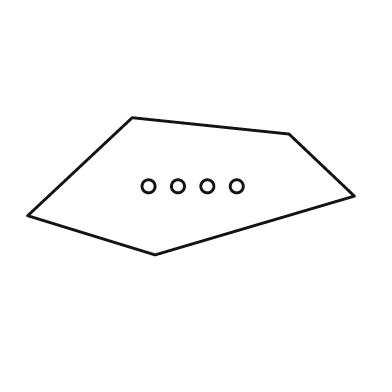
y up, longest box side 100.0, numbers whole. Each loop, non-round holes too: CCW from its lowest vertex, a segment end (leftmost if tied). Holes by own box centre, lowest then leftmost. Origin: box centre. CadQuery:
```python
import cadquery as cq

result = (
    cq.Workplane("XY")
    .moveTo(-11.0, -21.0)
    .lineTo(50.0, -3.0)
    .lineTo(30.0, 16.0)
    .lineTo(-18.0, 21.0)
    .lineTo(-50.0, -9.0)
    .close()
    .moveTo(-13.0, 0.0)
    .circle(2.0)
    .moveTo(-4.0, 0.0)
    .circle(2.0)
    .moveTo(5.0, 0.0)
    .circle(2.0)
    .moveTo(14.0, 0.0)
    .circle(2.0)
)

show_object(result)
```